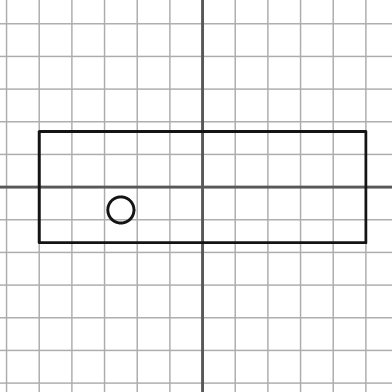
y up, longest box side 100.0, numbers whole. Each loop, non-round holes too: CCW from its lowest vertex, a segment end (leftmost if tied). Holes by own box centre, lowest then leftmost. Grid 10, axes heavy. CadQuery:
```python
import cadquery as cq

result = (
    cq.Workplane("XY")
    .moveTo(-50.0, -17.0)
    .lineTo(50.0, -17.0)
    .lineTo(50.0, 17.0)
    .lineTo(-50.0, 17.0)
    .close()
    .moveTo(-25.0, -7.0)
    .circle(4.0)
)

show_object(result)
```